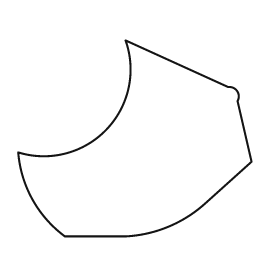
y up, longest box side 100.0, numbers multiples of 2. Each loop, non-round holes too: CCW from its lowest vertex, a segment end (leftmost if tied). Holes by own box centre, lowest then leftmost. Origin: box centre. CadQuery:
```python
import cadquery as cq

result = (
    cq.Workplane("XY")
    .moveTo(-30.0, -42.0)
    .lineTo(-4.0, -42.0)
    .threePointArc((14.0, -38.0), (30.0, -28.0))
    .lineTo(50.0, -10.0)
    .lineTo(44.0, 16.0)
    .threePointArc((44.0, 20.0), (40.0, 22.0))
    .lineTo(-4.0, 42.0)
    .threePointArc((-12.0, 4.0), (-50.0, -6.0))
    .threePointArc((-44.0, -26.0), (-30.0, -42.0))
    .close()
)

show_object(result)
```